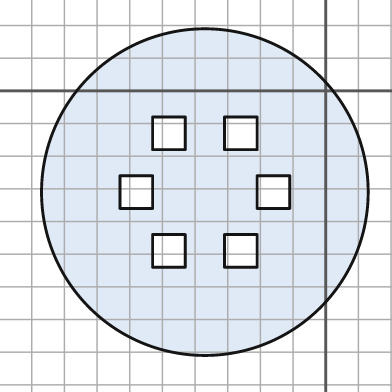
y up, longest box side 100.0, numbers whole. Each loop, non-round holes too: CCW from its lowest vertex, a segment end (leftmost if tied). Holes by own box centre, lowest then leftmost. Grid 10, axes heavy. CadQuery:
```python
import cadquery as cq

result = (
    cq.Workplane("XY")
    .moveTo(-37.0, -31.0)
    .circle(50.0)
    .moveTo(-53.0, -54.0)
    .lineTo(-43.0, -54.0)
    .lineTo(-43.0, -44.0)
    .lineTo(-53.0, -44.0)
    .close()
    .moveTo(-31.0, -54.0)
    .lineTo(-21.0, -54.0)
    .lineTo(-21.0, -44.0)
    .lineTo(-31.0, -44.0)
    .close()
    .moveTo(-63.0, -36.0)
    .lineTo(-53.0, -36.0)
    .lineTo(-53.0, -26.0)
    .lineTo(-63.0, -26.0)
    .close()
    .moveTo(-21.0, -36.0)
    .lineTo(-11.0, -36.0)
    .lineTo(-11.0, -26.0)
    .lineTo(-21.0, -26.0)
    .close()
    .moveTo(-53.0, -18.0)
    .lineTo(-43.0, -18.0)
    .lineTo(-43.0, -8.0)
    .lineTo(-53.0, -8.0)
    .close()
    .moveTo(-31.0, -18.0)
    .lineTo(-21.0, -18.0)
    .lineTo(-21.0, -8.0)
    .lineTo(-31.0, -8.0)
    .close()
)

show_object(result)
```